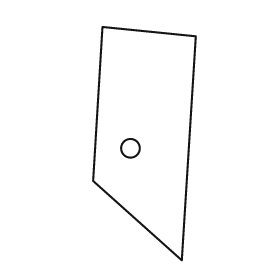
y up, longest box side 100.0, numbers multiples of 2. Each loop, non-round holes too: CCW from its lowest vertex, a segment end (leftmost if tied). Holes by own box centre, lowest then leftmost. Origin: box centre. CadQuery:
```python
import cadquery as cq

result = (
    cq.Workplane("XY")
    .moveTo(16.0, -50.0)
    .lineTo(22.0, 46.0)
    .lineTo(-18.0, 50.0)
    .lineTo(-22.0, -16.0)
    .close()
    .moveTo(-6.0, -2.0)
    .circle(4.0)
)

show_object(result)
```